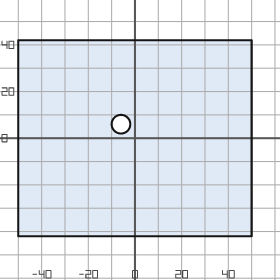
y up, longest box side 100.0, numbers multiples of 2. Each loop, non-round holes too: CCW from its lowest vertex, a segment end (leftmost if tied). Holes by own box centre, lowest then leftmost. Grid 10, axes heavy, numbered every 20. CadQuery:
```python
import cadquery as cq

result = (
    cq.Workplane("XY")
    .moveTo(-50.0, -42.0)
    .lineTo(50.0, -42.0)
    .lineTo(50.0, 42.0)
    .lineTo(-50.0, 42.0)
    .close()
    .moveTo(-6.0, 6.0)
    .circle(4.0)
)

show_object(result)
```